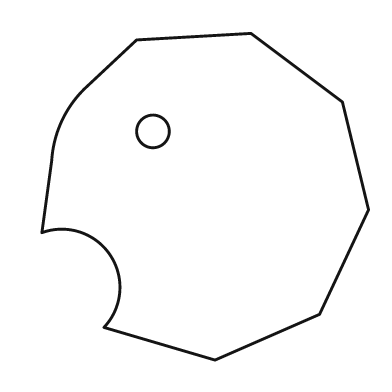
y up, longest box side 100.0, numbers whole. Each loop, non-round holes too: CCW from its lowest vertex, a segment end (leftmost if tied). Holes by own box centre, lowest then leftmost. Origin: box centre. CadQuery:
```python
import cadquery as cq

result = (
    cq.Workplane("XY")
    .moveTo(3.0, -50.0)
    .lineTo(35.0, -36.0)
    .lineTo(50.0, -4.0)
    .lineTo(42.0, 29.0)
    .lineTo(14.0, 50.0)
    .lineTo(-21.0, 48.0)
    .lineTo(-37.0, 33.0)
    .threePointArc((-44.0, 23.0), (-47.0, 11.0))
    .lineTo(-50.0, -11.0)
    .threePointArc((-29.0, -18.0), (-31.0, -40.0))
    .close()
    .moveTo(-16.0, 20.0)
    .circle(5.0)
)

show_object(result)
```